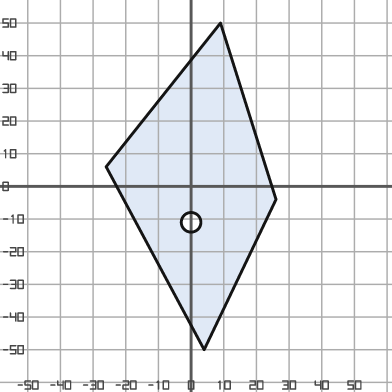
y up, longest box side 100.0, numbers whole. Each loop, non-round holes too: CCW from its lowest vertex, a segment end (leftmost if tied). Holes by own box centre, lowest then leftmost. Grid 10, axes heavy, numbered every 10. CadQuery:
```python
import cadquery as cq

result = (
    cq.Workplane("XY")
    .moveTo(4.0, -50.0)
    .lineTo(26.0, -4.0)
    .lineTo(9.0, 50.0)
    .lineTo(-26.0, 6.0)
    .close()
    .moveTo(0.0, -11.0)
    .circle(3.0)
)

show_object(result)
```